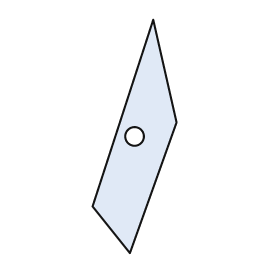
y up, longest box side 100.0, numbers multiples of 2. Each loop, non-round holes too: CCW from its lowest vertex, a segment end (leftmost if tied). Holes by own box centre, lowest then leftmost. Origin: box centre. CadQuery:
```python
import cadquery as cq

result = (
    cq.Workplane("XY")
    .moveTo(-2.0, -50.0)
    .lineTo(18.0, 6.0)
    .lineTo(8.0, 50.0)
    .lineTo(-18.0, -30.0)
    .close()
    .moveTo(0.0, 0.0)
    .circle(4.0)
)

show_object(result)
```